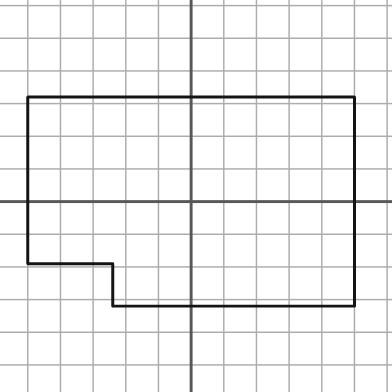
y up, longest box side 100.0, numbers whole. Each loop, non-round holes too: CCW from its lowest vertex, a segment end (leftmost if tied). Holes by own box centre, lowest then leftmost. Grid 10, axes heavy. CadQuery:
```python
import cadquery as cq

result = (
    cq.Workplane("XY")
    .moveTo(-24.0, -32.0)
    .lineTo(50.0, -32.0)
    .lineTo(50.0, 32.0)
    .lineTo(-50.0, 32.0)
    .lineTo(-50.0, -19.0)
    .lineTo(-24.0, -19.0)
    .close()
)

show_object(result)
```